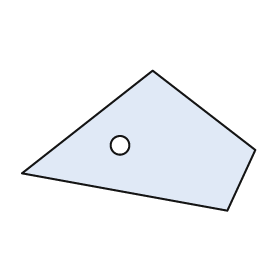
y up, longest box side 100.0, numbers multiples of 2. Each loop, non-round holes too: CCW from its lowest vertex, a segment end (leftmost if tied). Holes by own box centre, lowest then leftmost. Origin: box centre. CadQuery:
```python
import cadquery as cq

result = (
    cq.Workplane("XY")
    .moveTo(38.0, -30.0)
    .lineTo(50.0, -4.0)
    .lineTo(6.0, 30.0)
    .lineTo(-50.0, -14.0)
    .close()
    .moveTo(-8.0, -2.0)
    .circle(4.0)
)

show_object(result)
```